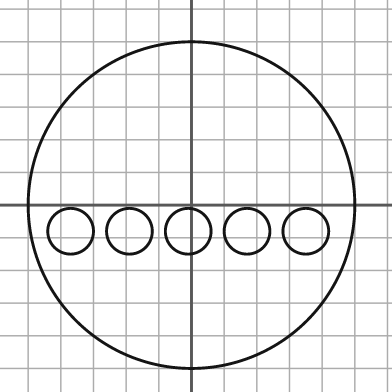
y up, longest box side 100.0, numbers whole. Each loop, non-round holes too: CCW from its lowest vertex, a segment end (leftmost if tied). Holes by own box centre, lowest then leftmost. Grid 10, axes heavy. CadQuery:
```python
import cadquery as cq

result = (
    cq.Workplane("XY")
    .moveTo(0.0, 0.0)
    .circle(50.0)
    .moveTo(-37.0, -8.0)
    .circle(7.0)
    .moveTo(-19.0, -8.0)
    .circle(7.0)
    .moveTo(-1.0, -8.0)
    .circle(7.0)
    .moveTo(17.0, -8.0)
    .circle(7.0)
    .moveTo(35.0, -8.0)
    .circle(7.0)
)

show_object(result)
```